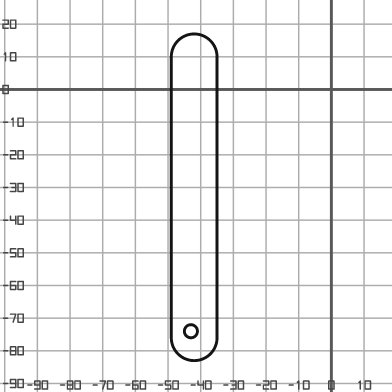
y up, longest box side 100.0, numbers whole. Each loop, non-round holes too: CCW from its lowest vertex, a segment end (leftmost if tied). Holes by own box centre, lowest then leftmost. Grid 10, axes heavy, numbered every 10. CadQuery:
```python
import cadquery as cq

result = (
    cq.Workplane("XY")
    .moveTo(-49.0, -76.0)
    .threePointArc((-42.0, -83.0), (-35.0, -76.0))
    .lineTo(-35.0, 10.0)
    .threePointArc((-42.0, 17.0), (-49.0, 10.0))
    .close()
    .moveTo(-43.0, -74.0)
    .circle(2.0)
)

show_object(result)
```